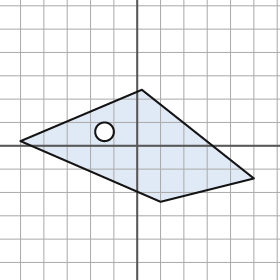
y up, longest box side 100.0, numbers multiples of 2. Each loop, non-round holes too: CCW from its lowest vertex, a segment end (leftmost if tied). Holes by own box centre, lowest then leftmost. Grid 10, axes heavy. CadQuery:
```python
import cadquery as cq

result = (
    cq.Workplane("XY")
    .moveTo(10.0, -24.0)
    .lineTo(50.0, -14.0)
    .lineTo(2.0, 24.0)
    .lineTo(-50.0, 2.0)
    .close()
    .moveTo(-14.0, 6.0)
    .circle(4.0)
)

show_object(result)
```